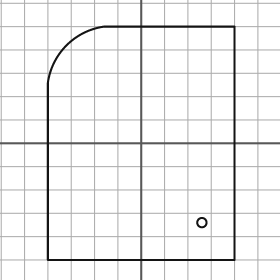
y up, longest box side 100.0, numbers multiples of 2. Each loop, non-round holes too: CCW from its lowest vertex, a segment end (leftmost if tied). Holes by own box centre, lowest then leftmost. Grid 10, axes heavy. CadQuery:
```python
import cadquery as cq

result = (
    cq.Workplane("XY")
    .moveTo(-40.0, -50.0)
    .lineTo(40.0, -50.0)
    .lineTo(40.0, 50.0)
    .lineTo(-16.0, 50.0)
    .threePointArc((-32.0, 42.0), (-40.0, 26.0))
    .close()
    .moveTo(26.0, -34.0)
    .circle(2.0)
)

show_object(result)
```